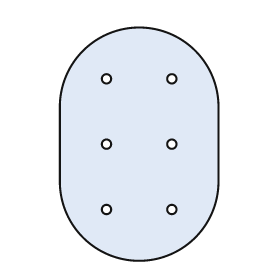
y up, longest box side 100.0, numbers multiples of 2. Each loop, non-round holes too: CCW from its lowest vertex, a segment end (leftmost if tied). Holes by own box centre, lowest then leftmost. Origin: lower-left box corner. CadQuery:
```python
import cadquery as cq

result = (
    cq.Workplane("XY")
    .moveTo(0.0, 34.0)
    .threePointArc((34.0, 0.0), (68.0, 34.0))
    .lineTo(68.0, 66.0)
    .threePointArc((34.0, 100.0), (0.0, 66.0))
    .close()
    .moveTo(20.0, 22.0)
    .circle(2.0)
    .moveTo(48.0, 22.0)
    .circle(2.0)
    .moveTo(20.0, 50.0)
    .circle(2.0)
    .moveTo(48.0, 50.0)
    .circle(2.0)
    .moveTo(20.0, 78.0)
    .circle(2.0)
    .moveTo(48.0, 78.0)
    .circle(2.0)
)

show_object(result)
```